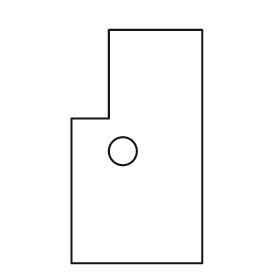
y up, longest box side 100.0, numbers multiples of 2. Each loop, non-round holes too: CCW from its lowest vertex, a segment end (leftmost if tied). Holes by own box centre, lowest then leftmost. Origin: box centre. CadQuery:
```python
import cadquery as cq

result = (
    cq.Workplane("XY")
    .moveTo(-28.0, -50.0)
    .lineTo(28.0, -50.0)
    .lineTo(28.0, 50.0)
    .lineTo(-12.0, 50.0)
    .lineTo(-12.0, 12.0)
    .lineTo(-28.0, 12.0)
    .close()
    .moveTo(-6.0, -2.0)
    .circle(6.0)
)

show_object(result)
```